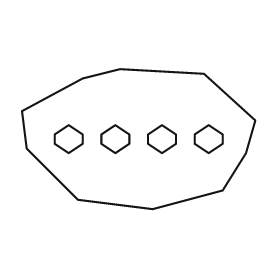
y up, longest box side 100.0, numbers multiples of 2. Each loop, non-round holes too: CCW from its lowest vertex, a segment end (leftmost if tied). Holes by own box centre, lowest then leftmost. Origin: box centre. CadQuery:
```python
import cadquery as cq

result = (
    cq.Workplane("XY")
    .moveTo(6.0, -30.0)
    .lineTo(36.0, -22.0)
    .lineTo(46.0, -6.0)
    .lineTo(50.0, 8.0)
    .lineTo(28.0, 28.0)
    .lineTo(-8.0, 30.0)
    .lineTo(-24.0, 26.0)
    .lineTo(-50.0, 12.0)
    .lineTo(-48.0, -4.0)
    .lineTo(-26.0, -26.0)
    .close()
    .moveTo(-30.0, -6.0)
    .lineTo(-24.0, -2.0)
    .lineTo(-24.0, 2.0)
    .lineTo(-30.0, 6.0)
    .lineTo(-36.0, 2.0)
    .lineTo(-36.0, -2.0)
    .close()
    .moveTo(-10.0, -6.0)
    .lineTo(-4.0, -2.0)
    .lineTo(-4.0, 2.0)
    .lineTo(-10.0, 6.0)
    .lineTo(-16.0, 2.0)
    .lineTo(-16.0, -2.0)
    .close()
    .moveTo(10.0, -6.0)
    .lineTo(16.0, -2.0)
    .lineTo(16.0, 2.0)
    .lineTo(10.0, 6.0)
    .lineTo(4.0, 2.0)
    .lineTo(4.0, -2.0)
    .close()
    .moveTo(30.0, -6.0)
    .lineTo(36.0, -2.0)
    .lineTo(36.0, 2.0)
    .lineTo(30.0, 6.0)
    .lineTo(24.0, 2.0)
    .lineTo(24.0, -2.0)
    .close()
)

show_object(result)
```